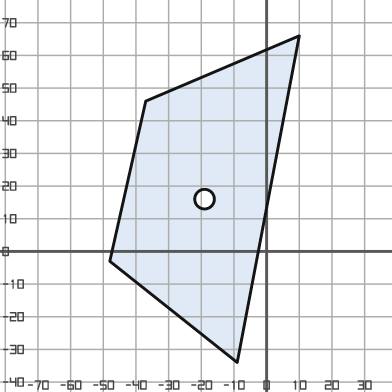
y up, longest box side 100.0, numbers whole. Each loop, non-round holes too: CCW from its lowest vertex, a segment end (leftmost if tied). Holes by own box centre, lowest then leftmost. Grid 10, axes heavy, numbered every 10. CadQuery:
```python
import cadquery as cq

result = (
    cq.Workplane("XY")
    .moveTo(-9.0, -34.0)
    .lineTo(10.0, 66.0)
    .lineTo(-37.0, 46.0)
    .lineTo(-48.0, -3.0)
    .close()
    .moveTo(-19.0, 16.0)
    .circle(3.0)
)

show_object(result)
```